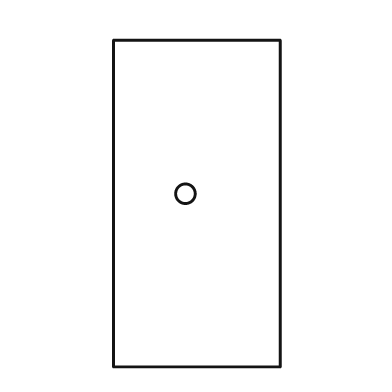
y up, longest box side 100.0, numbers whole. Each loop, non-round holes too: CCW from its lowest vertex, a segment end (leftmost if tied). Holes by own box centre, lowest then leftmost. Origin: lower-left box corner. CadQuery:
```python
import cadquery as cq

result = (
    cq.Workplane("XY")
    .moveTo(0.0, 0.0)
    .lineTo(51.0, 0.0)
    .lineTo(51.0, 100.0)
    .lineTo(0.0, 100.0)
    .close()
    .moveTo(22.0, 53.0)
    .circle(3.0)
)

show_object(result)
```